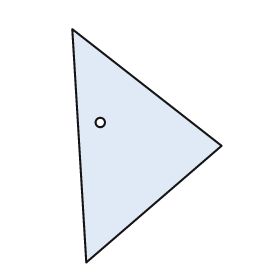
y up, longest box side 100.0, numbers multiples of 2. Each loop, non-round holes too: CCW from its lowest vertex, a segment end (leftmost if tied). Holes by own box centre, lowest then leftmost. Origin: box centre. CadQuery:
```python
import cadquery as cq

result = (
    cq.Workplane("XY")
    .moveTo(-26.0, -50.0)
    .lineTo(32.0, 0.0)
    .lineTo(-32.0, 50.0)
    .close()
    .moveTo(-20.0, 10.0)
    .circle(2.0)
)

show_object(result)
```